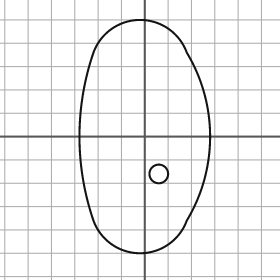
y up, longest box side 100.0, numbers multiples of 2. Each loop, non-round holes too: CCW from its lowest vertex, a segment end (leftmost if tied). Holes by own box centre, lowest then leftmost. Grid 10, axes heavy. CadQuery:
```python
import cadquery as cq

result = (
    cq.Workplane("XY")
    .moveTo(-22.0, -36.0)
    .threePointArc((-2.0, -50.0), (18.0, -36.0))
    .threePointArc((28.0, 0.0), (18.0, 36.0))
    .threePointArc((-2.0, 50.0), (-22.0, 36.0))
    .threePointArc((-28.0, 0.0), (-22.0, -36.0))
    .close()
    .moveTo(6.0, -16.0)
    .circle(4.0)
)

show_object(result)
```